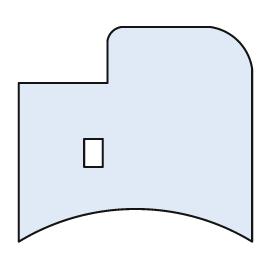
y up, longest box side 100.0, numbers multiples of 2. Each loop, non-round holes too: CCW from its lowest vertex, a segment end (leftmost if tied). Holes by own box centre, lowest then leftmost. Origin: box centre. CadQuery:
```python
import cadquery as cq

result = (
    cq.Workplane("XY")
    .moveTo(-50.0, -46.0)
    .threePointArc((0.0, -32.0), (50.0, -46.0))
    .lineTo(50.0, 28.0)
    .threePointArc((44.0, 40.0), (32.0, 46.0))
    .lineTo(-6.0, 46.0)
    .threePointArc((-10.0, 44.0), (-12.0, 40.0))
    .lineTo(-12.0, 22.0)
    .lineTo(-50.0, 22.0)
    .close()
    .moveTo(-22.0, -14.0)
    .lineTo(-14.0, -14.0)
    .lineTo(-14.0, -2.0)
    .lineTo(-22.0, -2.0)
    .close()
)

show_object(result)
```